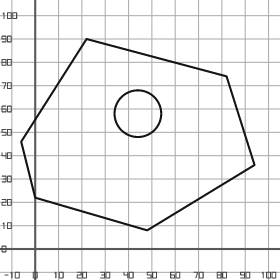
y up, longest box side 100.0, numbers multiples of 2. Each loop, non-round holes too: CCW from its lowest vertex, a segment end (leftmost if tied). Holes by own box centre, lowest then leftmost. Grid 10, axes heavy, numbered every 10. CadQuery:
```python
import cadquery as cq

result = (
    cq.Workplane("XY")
    .moveTo(48.0, 8.0)
    .lineTo(94.0, 36.0)
    .lineTo(82.0, 74.0)
    .lineTo(22.0, 90.0)
    .lineTo(-6.0, 46.0)
    .lineTo(0.0, 22.0)
    .close()
    .moveTo(44.0, 58.0)
    .circle(10.0)
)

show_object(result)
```